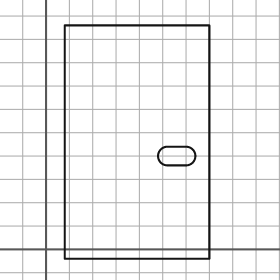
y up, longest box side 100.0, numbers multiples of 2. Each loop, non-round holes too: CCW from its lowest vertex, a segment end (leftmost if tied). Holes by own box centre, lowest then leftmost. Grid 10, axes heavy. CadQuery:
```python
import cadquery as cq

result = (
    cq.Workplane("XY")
    .moveTo(8.0, -4.0)
    .lineTo(70.0, -4.0)
    .lineTo(70.0, 96.0)
    .lineTo(8.0, 96.0)
    .close()
    .moveTo(52.0, 36.0)
    .lineTo(60.0, 36.0)
    .threePointArc((64.0, 40.0), (60.0, 44.0))
    .lineTo(52.0, 44.0)
    .threePointArc((48.0, 40.0), (52.0, 36.0))
    .close()
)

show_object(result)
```